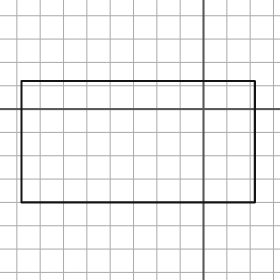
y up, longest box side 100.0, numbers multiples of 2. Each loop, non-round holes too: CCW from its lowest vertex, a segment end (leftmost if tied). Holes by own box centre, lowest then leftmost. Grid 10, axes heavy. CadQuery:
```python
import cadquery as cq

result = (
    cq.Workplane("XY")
    .moveTo(-78.0, -40.0)
    .lineTo(22.0, -40.0)
    .lineTo(22.0, 12.0)
    .lineTo(-78.0, 12.0)
    .close()
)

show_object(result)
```